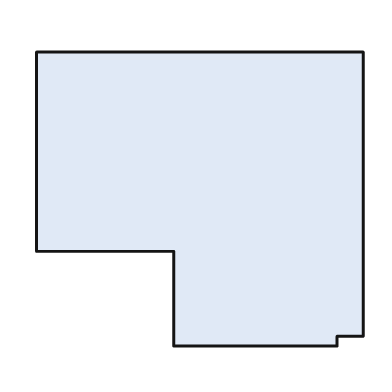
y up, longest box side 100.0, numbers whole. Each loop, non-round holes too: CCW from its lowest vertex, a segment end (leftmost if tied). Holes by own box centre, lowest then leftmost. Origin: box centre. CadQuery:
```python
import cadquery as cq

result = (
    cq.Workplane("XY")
    .moveTo(-8.0, -45.0)
    .lineTo(42.0, -45.0)
    .lineTo(42.0, -42.0)
    .lineTo(50.0, -42.0)
    .lineTo(50.0, 45.0)
    .lineTo(-50.0, 45.0)
    .lineTo(-50.0, -16.0)
    .lineTo(-8.0, -16.0)
    .close()
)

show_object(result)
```